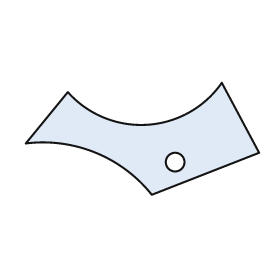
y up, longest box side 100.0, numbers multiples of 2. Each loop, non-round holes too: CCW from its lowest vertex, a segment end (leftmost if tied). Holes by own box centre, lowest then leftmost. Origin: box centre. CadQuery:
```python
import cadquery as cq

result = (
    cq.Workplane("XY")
    .moveTo(4.0, -24.0)
    .lineTo(50.0, -6.0)
    .lineTo(34.0, 24.0)
    .threePointArc((2.0, 6.0), (-32.0, 20.0))
    .lineTo(-50.0, -2.0)
    .threePointArc((-20.0, -6.0), (4.0, -24.0))
    .close()
    .moveTo(14.0, -10.0)
    .circle(4.0)
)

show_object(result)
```